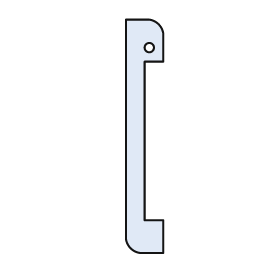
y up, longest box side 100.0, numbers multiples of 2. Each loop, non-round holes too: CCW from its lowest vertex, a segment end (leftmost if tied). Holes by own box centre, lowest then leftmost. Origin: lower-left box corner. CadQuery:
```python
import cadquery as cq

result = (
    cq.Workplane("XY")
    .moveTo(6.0, 0.0)
    .lineTo(16.0, 0.0)
    .lineTo(16.0, 14.0)
    .lineTo(8.0, 14.0)
    .lineTo(8.0, 82.0)
    .lineTo(16.0, 82.0)
    .lineTo(16.0, 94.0)
    .threePointArc((14.0, 98.0), (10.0, 100.0))
    .lineTo(0.0, 100.0)
    .lineTo(0.0, 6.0)
    .threePointArc((2.0, 2.0), (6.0, 0.0))
    .close()
    .moveTo(10.0, 88.0)
    .circle(2.0)
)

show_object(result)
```